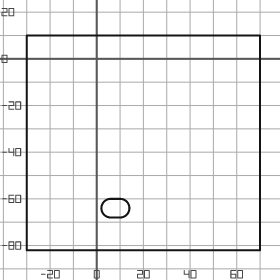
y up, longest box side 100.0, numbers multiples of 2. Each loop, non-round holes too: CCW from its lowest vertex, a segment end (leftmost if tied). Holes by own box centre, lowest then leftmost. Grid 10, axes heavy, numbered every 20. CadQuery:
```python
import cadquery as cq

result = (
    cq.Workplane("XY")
    .moveTo(-30.0, -82.0)
    .lineTo(70.0, -82.0)
    .lineTo(70.0, 10.0)
    .lineTo(-30.0, 10.0)
    .close()
    .moveTo(6.0, -68.0)
    .lineTo(10.0, -68.0)
    .threePointArc((14.0, -64.0), (10.0, -60.0))
    .lineTo(6.0, -60.0)
    .threePointArc((2.0, -64.0), (6.0, -68.0))
    .close()
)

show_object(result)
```